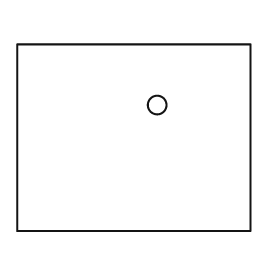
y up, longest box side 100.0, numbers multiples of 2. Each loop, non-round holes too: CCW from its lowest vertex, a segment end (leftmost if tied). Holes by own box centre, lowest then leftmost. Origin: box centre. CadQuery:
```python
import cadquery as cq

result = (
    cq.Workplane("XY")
    .moveTo(-50.0, -40.0)
    .lineTo(50.0, -40.0)
    .lineTo(50.0, 40.0)
    .lineTo(-50.0, 40.0)
    .close()
    .moveTo(10.0, 14.0)
    .circle(4.0)
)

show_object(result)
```